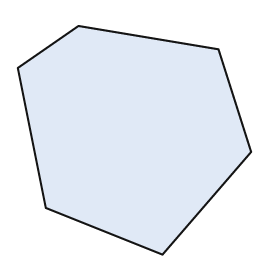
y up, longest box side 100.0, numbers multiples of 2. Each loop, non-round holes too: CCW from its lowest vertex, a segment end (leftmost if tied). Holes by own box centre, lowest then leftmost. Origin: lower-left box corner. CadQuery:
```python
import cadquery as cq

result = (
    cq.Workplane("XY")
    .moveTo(62.0, 0.0)
    .lineTo(100.0, 44.0)
    .lineTo(86.0, 88.0)
    .lineTo(26.0, 98.0)
    .lineTo(0.0, 80.0)
    .lineTo(12.0, 20.0)
    .close()
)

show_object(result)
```